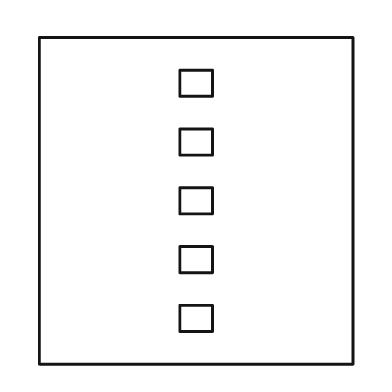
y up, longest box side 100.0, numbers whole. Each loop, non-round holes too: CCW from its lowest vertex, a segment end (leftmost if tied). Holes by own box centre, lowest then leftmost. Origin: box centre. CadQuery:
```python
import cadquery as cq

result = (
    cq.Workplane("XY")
    .moveTo(-48.0, -50.0)
    .lineTo(48.0, -50.0)
    .lineTo(48.0, 50.0)
    .lineTo(-48.0, 50.0)
    .close()
    .moveTo(-5.0, -40.0)
    .lineTo(5.0, -40.0)
    .lineTo(5.0, -32.0)
    .lineTo(-5.0, -32.0)
    .close()
    .moveTo(-5.0, -22.0)
    .lineTo(5.0, -22.0)
    .lineTo(5.0, -14.0)
    .lineTo(-5.0, -14.0)
    .close()
    .moveTo(-5.0, -4.0)
    .lineTo(5.0, -4.0)
    .lineTo(5.0, 4.0)
    .lineTo(-5.0, 4.0)
    .close()
    .moveTo(-5.0, 14.0)
    .lineTo(5.0, 14.0)
    .lineTo(5.0, 22.0)
    .lineTo(-5.0, 22.0)
    .close()
    .moveTo(-5.0, 32.0)
    .lineTo(5.0, 32.0)
    .lineTo(5.0, 40.0)
    .lineTo(-5.0, 40.0)
    .close()
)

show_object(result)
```